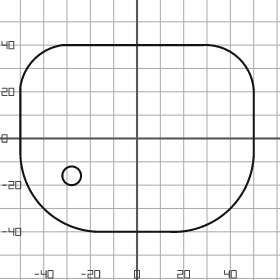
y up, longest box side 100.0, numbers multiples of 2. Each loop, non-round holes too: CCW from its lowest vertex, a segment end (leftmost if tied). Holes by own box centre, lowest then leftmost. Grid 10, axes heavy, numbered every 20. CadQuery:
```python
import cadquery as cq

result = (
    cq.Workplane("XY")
    .moveTo(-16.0, -40.0)
    .lineTo(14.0, -40.0)
    .threePointArc((40.0, -30.0), (50.0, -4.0))
    .lineTo(50.0, 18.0)
    .threePointArc((44.0, 34.0), (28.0, 40.0))
    .lineTo(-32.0, 40.0)
    .threePointArc((-44.0, 34.0), (-50.0, 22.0))
    .lineTo(-50.0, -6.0)
    .threePointArc((-40.0, -30.0), (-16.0, -40.0))
    .close()
    .moveTo(-28.0, -16.0)
    .circle(4.0)
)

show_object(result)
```